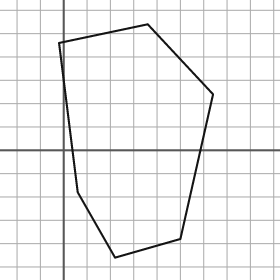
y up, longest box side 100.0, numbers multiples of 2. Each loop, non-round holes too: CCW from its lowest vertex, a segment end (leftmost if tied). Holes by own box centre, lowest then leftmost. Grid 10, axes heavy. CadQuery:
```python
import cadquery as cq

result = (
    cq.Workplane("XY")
    .moveTo(22.0, -46.0)
    .lineTo(50.0, -38.0)
    .lineTo(64.0, 24.0)
    .lineTo(36.0, 54.0)
    .lineTo(-2.0, 46.0)
    .lineTo(6.0, -18.0)
    .close()
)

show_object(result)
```